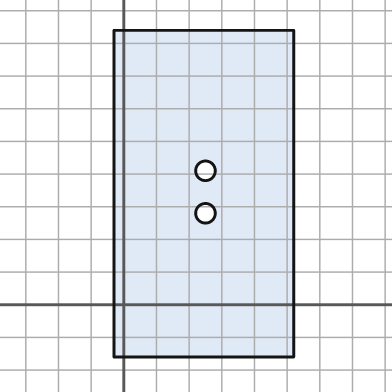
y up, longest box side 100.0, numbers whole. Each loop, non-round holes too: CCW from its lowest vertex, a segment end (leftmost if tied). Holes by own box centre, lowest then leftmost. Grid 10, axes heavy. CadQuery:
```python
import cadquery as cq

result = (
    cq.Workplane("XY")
    .moveTo(-3.0, -16.0)
    .lineTo(52.0, -16.0)
    .lineTo(52.0, 84.0)
    .lineTo(-3.0, 84.0)
    .close()
    .moveTo(25.0, 28.0)
    .circle(3.0)
    .moveTo(25.0, 41.0)
    .circle(3.0)
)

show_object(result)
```